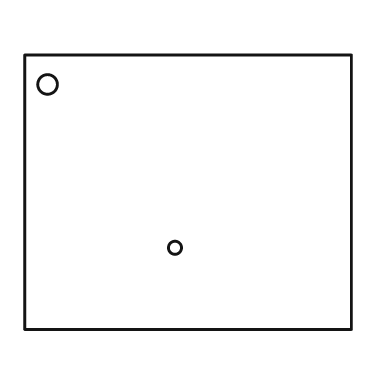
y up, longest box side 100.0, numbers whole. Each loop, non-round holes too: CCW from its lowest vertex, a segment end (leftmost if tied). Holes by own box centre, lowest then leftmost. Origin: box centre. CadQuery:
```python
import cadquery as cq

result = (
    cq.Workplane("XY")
    .moveTo(-50.0, -42.0)
    .lineTo(50.0, -42.0)
    .lineTo(50.0, 42.0)
    .lineTo(-50.0, 42.0)
    .close()
    .moveTo(-4.0, -17.0)
    .circle(2.0)
    .moveTo(-43.0, 33.0)
    .circle(3.0)
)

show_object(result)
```